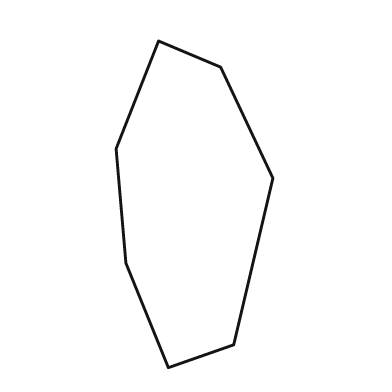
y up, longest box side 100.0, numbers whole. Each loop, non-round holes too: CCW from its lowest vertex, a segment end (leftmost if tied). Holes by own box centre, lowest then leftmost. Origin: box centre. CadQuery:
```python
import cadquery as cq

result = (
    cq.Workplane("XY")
    .moveTo(-8.0, -50.0)
    .lineTo(12.0, -43.0)
    .lineTo(24.0, 8.0)
    .lineTo(8.0, 42.0)
    .lineTo(-11.0, 50.0)
    .lineTo(-24.0, 17.0)
    .lineTo(-21.0, -18.0)
    .close()
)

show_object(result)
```